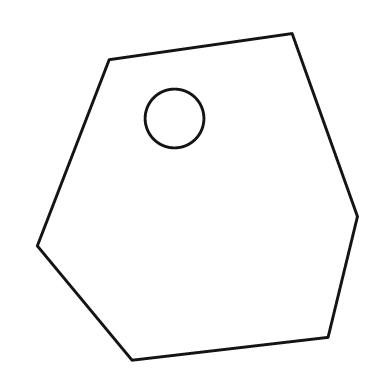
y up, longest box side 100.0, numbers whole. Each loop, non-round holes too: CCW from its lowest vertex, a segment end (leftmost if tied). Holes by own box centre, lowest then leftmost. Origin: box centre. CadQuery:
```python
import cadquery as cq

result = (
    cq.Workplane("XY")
    .moveTo(-20.0, -50.0)
    .lineTo(40.0, -43.0)
    .lineTo(49.0, -6.0)
    .lineTo(29.0, 50.0)
    .lineTo(-27.0, 42.0)
    .lineTo(-49.0, -15.0)
    .close()
    .moveTo(-7.0, 24.0)
    .circle(9.0)
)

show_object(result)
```